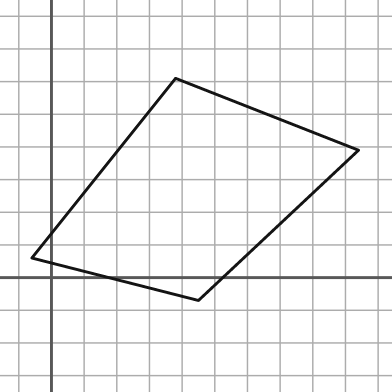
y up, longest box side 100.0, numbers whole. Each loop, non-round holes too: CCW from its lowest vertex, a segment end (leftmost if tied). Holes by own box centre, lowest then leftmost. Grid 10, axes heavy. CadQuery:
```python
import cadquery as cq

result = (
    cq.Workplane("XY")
    .moveTo(45.0, -7.0)
    .lineTo(94.0, 39.0)
    .lineTo(38.0, 61.0)
    .lineTo(-6.0, 6.0)
    .close()
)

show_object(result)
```